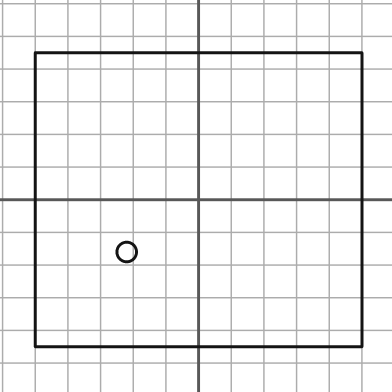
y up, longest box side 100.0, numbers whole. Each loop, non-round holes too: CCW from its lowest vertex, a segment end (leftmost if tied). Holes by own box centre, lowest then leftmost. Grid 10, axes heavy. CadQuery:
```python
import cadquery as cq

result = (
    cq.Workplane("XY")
    .moveTo(-50.0, -45.0)
    .lineTo(50.0, -45.0)
    .lineTo(50.0, 45.0)
    .lineTo(-50.0, 45.0)
    .close()
    .moveTo(-22.0, -16.0)
    .circle(3.0)
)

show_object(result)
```